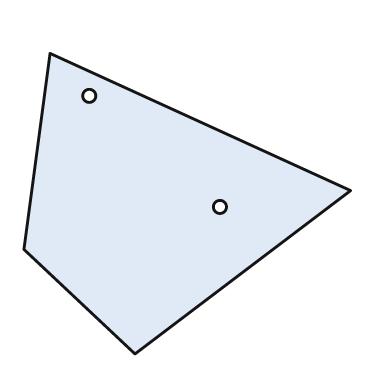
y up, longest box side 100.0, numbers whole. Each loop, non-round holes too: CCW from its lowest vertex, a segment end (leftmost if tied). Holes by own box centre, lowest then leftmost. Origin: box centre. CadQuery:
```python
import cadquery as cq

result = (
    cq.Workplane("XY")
    .moveTo(-16.0, -46.0)
    .lineTo(50.0, 4.0)
    .lineTo(-42.0, 46.0)
    .lineTo(-50.0, -14.0)
    .close()
    .moveTo(10.0, -1.0)
    .circle(2.0)
    .moveTo(-30.0, 33.0)
    .circle(2.0)
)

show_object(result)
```